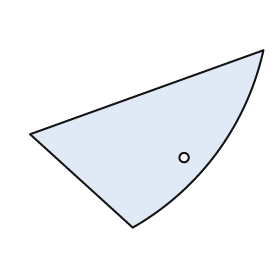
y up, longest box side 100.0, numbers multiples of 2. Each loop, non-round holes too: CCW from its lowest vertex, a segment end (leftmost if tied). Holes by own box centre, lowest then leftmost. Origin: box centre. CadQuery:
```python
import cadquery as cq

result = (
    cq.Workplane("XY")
    .moveTo(-6.0, -38.0)
    .threePointArc((30.0, -6.0), (50.0, 38.0))
    .lineTo(-50.0, 2.0)
    .close()
    .moveTo(16.0, -8.0)
    .circle(2.0)
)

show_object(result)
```